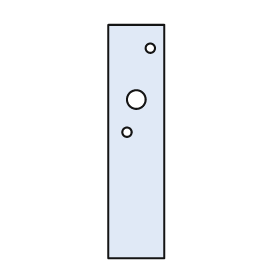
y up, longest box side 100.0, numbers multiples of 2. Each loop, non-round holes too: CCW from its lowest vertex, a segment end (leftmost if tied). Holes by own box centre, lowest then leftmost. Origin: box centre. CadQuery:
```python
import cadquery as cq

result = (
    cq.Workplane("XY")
    .moveTo(-12.0, -50.0)
    .lineTo(12.0, -50.0)
    .lineTo(12.0, 50.0)
    .lineTo(-12.0, 50.0)
    .close()
    .moveTo(-4.0, 4.0)
    .circle(2.0)
    .moveTo(0.0, 18.0)
    .circle(4.0)
    .moveTo(6.0, 40.0)
    .circle(2.0)
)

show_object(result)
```